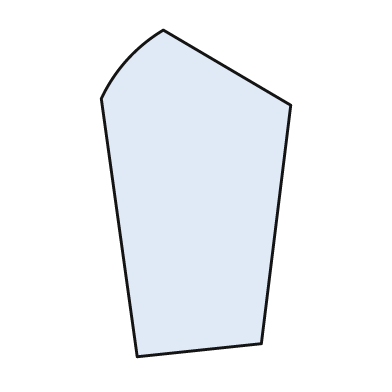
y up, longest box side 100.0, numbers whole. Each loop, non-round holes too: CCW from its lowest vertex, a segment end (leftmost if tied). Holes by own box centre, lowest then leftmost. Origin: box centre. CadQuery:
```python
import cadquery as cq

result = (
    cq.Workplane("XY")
    .moveTo(-18.0, -50.0)
    .lineTo(20.0, -46.0)
    .lineTo(29.0, 27.0)
    .lineTo(-10.0, 50.0)
    .threePointArc((-21.0, 41.0), (-29.0, 29.0))
    .close()
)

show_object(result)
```